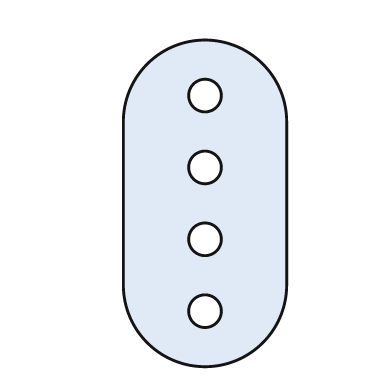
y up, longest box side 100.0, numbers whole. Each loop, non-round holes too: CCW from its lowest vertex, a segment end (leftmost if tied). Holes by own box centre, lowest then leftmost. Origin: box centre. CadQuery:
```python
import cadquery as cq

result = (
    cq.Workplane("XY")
    .moveTo(-25.0, -25.0)
    .threePointArc((0.0, -50.0), (25.0, -25.0))
    .lineTo(25.0, 25.0)
    .threePointArc((0.0, 50.0), (-25.0, 25.0))
    .close()
    .moveTo(0.0, -33.0)
    .circle(5.0)
    .moveTo(0.0, -11.0)
    .circle(5.0)
    .moveTo(0.0, 11.0)
    .circle(5.0)
    .moveTo(0.0, 33.0)
    .circle(5.0)
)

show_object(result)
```